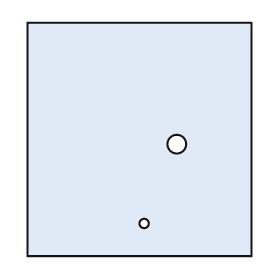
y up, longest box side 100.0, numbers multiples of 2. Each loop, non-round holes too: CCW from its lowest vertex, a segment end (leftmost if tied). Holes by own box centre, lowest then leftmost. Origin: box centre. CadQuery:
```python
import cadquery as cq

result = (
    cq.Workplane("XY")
    .moveTo(-48.0, -50.0)
    .lineTo(48.0, -50.0)
    .lineTo(48.0, 50.0)
    .lineTo(-48.0, 50.0)
    .close()
    .moveTo(2.0, -36.0)
    .circle(2.0)
    .moveTo(16.0, -2.0)
    .circle(4.0)
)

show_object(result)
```